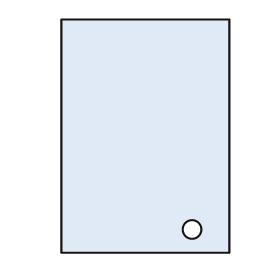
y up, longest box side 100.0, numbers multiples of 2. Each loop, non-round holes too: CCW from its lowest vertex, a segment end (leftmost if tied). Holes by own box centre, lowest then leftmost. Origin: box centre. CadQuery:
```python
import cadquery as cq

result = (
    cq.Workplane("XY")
    .moveTo(-36.0, -50.0)
    .lineTo(36.0, -50.0)
    .lineTo(36.0, 50.0)
    .lineTo(-36.0, 50.0)
    .close()
    .moveTo(20.0, -40.0)
    .circle(4.0)
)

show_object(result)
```